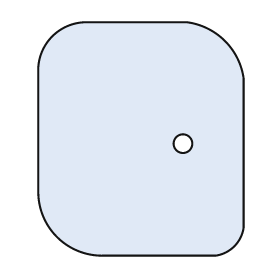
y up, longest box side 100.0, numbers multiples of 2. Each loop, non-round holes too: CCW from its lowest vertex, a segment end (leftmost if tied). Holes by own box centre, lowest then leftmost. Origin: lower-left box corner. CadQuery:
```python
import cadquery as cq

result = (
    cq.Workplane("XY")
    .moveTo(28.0, 0.0)
    .lineTo(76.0, 0.0)
    .threePointArc((84.0, 4.0), (88.0, 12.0))
    .lineTo(88.0, 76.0)
    .threePointArc((80.0, 92.0), (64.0, 100.0))
    .lineTo(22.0, 100.0)
    .threePointArc((6.0, 94.0), (0.0, 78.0))
    .lineTo(0.0, 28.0)
    .threePointArc((8.0, 8.0), (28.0, 0.0))
    .close()
    .moveTo(62.0, 48.0)
    .circle(4.0)
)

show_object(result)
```